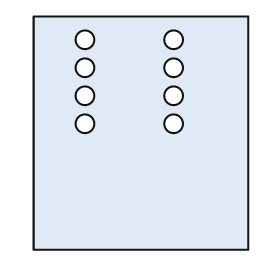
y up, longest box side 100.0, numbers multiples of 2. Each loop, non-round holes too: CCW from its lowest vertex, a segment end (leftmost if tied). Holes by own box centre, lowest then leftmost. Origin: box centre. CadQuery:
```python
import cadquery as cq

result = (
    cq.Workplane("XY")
    .moveTo(-46.0, -50.0)
    .lineTo(46.0, -50.0)
    .lineTo(46.0, 50.0)
    .lineTo(-46.0, 50.0)
    .close()
    .moveTo(-24.0, 4.0)
    .circle(4.0)
    .moveTo(14.0, 4.0)
    .circle(4.0)
    .moveTo(-24.0, 16.0)
    .circle(4.0)
    .moveTo(14.0, 16.0)
    .circle(4.0)
    .moveTo(-24.0, 28.0)
    .circle(4.0)
    .moveTo(14.0, 28.0)
    .circle(4.0)
    .moveTo(-24.0, 40.0)
    .circle(4.0)
    .moveTo(14.0, 40.0)
    .circle(4.0)
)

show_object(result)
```